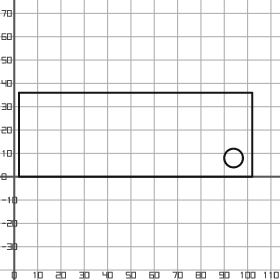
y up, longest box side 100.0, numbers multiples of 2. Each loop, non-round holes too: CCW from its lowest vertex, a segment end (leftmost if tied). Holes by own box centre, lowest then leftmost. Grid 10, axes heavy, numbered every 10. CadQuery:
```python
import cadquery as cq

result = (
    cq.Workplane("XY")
    .moveTo(2.0, 0.0)
    .lineTo(102.0, 0.0)
    .lineTo(102.0, 36.0)
    .lineTo(2.0, 36.0)
    .close()
    .moveTo(94.0, 8.0)
    .circle(4.0)
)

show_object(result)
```